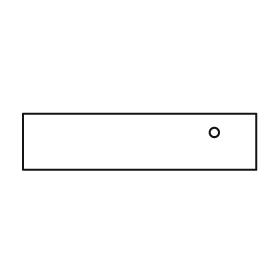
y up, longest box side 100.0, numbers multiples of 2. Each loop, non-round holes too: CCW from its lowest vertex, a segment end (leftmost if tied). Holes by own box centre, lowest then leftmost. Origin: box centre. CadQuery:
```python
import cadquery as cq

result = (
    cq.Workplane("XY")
    .moveTo(-50.0, -12.0)
    .lineTo(50.0, -12.0)
    .lineTo(50.0, 12.0)
    .lineTo(-50.0, 12.0)
    .close()
    .moveTo(32.0, 4.0)
    .circle(2.0)
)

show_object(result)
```